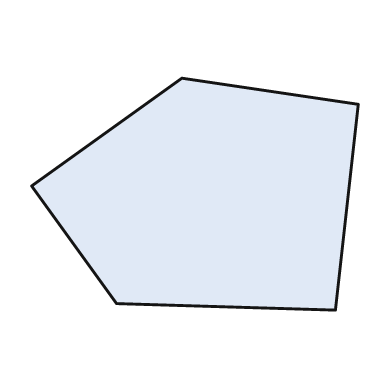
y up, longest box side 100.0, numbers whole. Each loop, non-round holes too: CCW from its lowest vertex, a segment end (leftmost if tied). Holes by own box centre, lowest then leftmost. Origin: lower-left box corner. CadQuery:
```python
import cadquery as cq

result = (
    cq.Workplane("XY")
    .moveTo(93.0, 0.0)
    .lineTo(100.0, 63.0)
    .lineTo(46.0, 71.0)
    .lineTo(0.0, 38.0)
    .lineTo(26.0, 2.0)
    .close()
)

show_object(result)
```